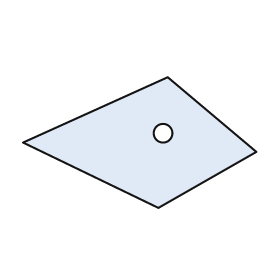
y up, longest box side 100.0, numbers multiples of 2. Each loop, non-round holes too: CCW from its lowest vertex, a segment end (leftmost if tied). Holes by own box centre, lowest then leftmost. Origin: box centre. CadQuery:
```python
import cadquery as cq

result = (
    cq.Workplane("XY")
    .moveTo(8.0, -28.0)
    .lineTo(50.0, -4.0)
    .lineTo(12.0, 28.0)
    .lineTo(-50.0, 0.0)
    .close()
    .moveTo(10.0, 4.0)
    .circle(4.0)
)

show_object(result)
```